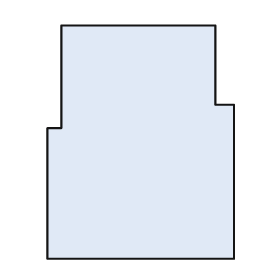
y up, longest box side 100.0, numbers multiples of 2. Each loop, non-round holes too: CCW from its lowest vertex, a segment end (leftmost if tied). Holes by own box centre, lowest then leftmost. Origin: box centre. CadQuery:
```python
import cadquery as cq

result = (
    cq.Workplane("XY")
    .moveTo(-40.0, -50.0)
    .lineTo(40.0, -50.0)
    .lineTo(40.0, 16.0)
    .lineTo(32.0, 16.0)
    .lineTo(32.0, 50.0)
    .lineTo(-34.0, 50.0)
    .lineTo(-34.0, 6.0)
    .lineTo(-40.0, 6.0)
    .close()
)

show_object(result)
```